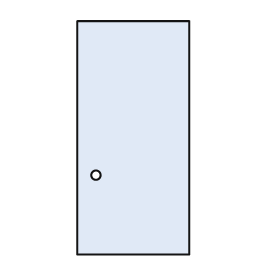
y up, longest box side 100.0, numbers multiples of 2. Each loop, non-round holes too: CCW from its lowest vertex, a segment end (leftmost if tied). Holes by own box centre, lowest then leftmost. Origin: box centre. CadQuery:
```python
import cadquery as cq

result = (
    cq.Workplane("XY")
    .moveTo(-24.0, -50.0)
    .lineTo(24.0, -50.0)
    .lineTo(24.0, 50.0)
    .lineTo(-24.0, 50.0)
    .close()
    .moveTo(-16.0, -16.0)
    .circle(2.0)
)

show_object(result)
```